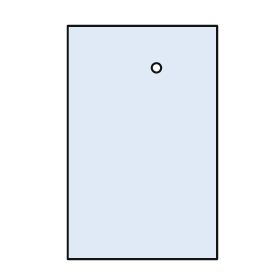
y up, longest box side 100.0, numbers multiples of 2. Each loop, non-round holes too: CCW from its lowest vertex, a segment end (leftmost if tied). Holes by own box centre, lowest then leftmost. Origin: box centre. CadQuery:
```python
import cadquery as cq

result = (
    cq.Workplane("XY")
    .moveTo(-32.0, -50.0)
    .lineTo(32.0, -50.0)
    .lineTo(32.0, 50.0)
    .lineTo(-32.0, 50.0)
    .close()
    .moveTo(6.0, 32.0)
    .circle(2.0)
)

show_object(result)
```